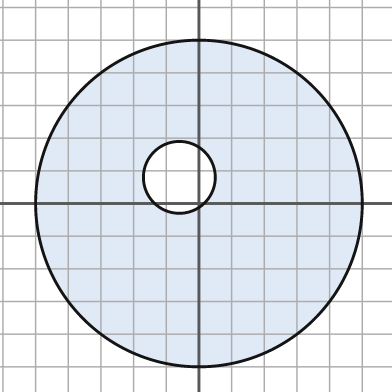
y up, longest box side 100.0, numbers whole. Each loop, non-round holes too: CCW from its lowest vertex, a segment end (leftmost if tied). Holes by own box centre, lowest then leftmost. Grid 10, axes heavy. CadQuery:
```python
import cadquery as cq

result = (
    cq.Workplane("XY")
    .moveTo(0.0, 0.0)
    .circle(50.0)
    .moveTo(-6.0, 8.0)
    .circle(11.0)
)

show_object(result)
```